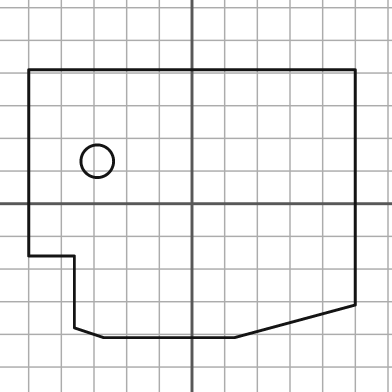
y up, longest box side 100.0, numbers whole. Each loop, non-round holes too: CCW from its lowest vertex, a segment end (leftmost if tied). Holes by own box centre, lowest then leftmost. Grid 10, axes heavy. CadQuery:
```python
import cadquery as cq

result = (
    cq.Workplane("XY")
    .moveTo(-27.0, -41.0)
    .lineTo(13.0, -41.0)
    .lineTo(50.0, -31.0)
    .lineTo(50.0, 41.0)
    .lineTo(-50.0, 41.0)
    .lineTo(-50.0, -16.0)
    .lineTo(-36.0, -16.0)
    .lineTo(-36.0, -38.0)
    .close()
    .moveTo(-29.0, 13.0)
    .circle(5.0)
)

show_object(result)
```